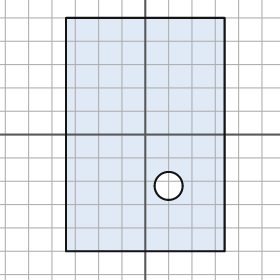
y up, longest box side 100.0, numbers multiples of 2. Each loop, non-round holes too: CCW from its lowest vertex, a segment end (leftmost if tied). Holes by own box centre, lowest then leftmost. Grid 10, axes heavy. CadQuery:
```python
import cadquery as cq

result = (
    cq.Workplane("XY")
    .moveTo(-34.0, -50.0)
    .lineTo(34.0, -50.0)
    .lineTo(34.0, 50.0)
    .lineTo(-34.0, 50.0)
    .close()
    .moveTo(10.0, -22.0)
    .circle(6.0)
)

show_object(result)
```